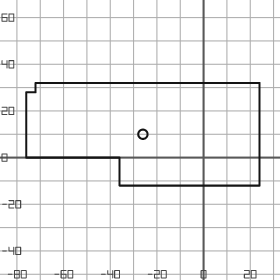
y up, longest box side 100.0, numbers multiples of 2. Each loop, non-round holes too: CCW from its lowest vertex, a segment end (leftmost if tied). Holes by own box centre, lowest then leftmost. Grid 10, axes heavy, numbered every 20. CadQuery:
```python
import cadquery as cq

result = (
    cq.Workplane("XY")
    .moveTo(-36.0, -12.0)
    .lineTo(24.0, -12.0)
    .lineTo(24.0, 32.0)
    .lineTo(-72.0, 32.0)
    .lineTo(-72.0, 28.0)
    .lineTo(-76.0, 28.0)
    .lineTo(-76.0, 0.0)
    .lineTo(-36.0, 0.0)
    .close()
    .moveTo(-26.0, 10.0)
    .circle(2.0)
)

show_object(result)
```